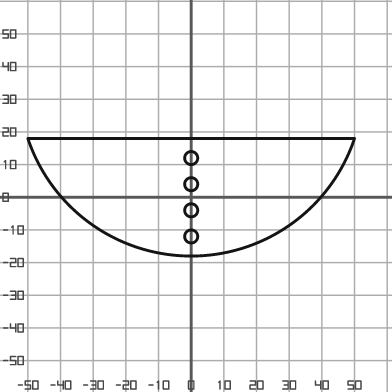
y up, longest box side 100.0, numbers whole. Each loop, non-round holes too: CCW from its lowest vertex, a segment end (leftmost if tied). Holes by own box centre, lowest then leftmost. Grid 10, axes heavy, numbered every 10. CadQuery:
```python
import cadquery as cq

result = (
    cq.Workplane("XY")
    .moveTo(-50.0, 18.0)
    .threePointArc((0.0, -18.0), (50.0, 18.0))
    .close()
    .moveTo(0.0, -12.0)
    .circle(2.0)
    .moveTo(0.0, -4.0)
    .circle(2.0)
    .moveTo(0.0, 4.0)
    .circle(2.0)
    .moveTo(0.0, 12.0)
    .circle(2.0)
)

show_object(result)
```